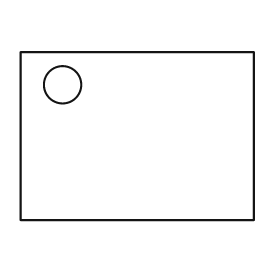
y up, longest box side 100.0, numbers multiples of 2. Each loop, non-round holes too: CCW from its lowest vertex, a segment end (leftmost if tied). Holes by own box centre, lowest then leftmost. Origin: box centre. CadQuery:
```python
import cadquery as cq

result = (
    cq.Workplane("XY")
    .moveTo(-50.0, -36.0)
    .lineTo(50.0, -36.0)
    .lineTo(50.0, 36.0)
    .lineTo(-50.0, 36.0)
    .close()
    .moveTo(-32.0, 22.0)
    .circle(8.0)
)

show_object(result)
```